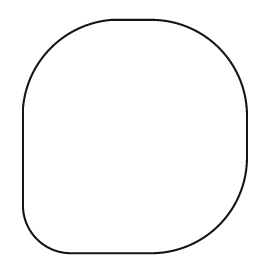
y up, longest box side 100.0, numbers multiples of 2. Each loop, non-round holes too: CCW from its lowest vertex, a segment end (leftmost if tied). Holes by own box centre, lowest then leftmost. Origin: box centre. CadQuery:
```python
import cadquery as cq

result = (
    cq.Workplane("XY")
    .moveTo(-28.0, -50.0)
    .lineTo(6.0, -50.0)
    .threePointArc((36.0, -38.0), (48.0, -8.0))
    .lineTo(48.0, 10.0)
    .threePointArc((36.0, 38.0), (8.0, 50.0))
    .lineTo(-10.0, 50.0)
    .threePointArc((-36.0, 38.0), (-48.0, 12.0))
    .lineTo(-48.0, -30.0)
    .threePointArc((-42.0, -44.0), (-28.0, -50.0))
    .close()
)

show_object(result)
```